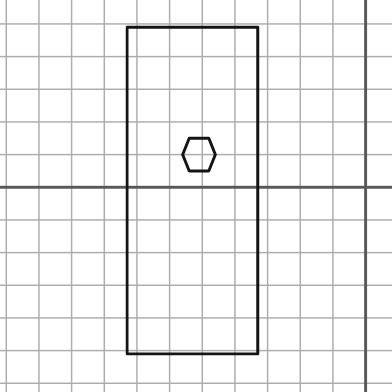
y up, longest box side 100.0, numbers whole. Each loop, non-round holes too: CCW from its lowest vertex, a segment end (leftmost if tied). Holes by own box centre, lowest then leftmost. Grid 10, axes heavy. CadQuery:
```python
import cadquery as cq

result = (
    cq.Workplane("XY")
    .moveTo(-73.0, -51.0)
    .lineTo(-33.0, -51.0)
    .lineTo(-33.0, 49.0)
    .lineTo(-73.0, 49.0)
    .close()
    .moveTo(-54.0, 5.0)
    .lineTo(-48.0, 5.0)
    .lineTo(-46.0, 10.0)
    .lineTo(-48.0, 15.0)
    .lineTo(-54.0, 15.0)
    .lineTo(-56.0, 10.0)
    .close()
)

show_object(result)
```